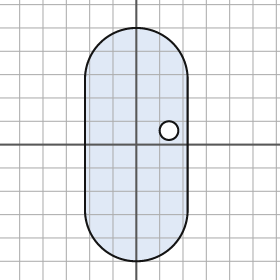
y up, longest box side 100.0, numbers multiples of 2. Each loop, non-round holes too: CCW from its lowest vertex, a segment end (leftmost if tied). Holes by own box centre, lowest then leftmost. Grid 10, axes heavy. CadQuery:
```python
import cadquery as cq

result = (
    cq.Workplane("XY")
    .moveTo(-22.0, -28.0)
    .threePointArc((0.0, -50.0), (22.0, -28.0))
    .lineTo(22.0, 28.0)
    .threePointArc((0.0, 50.0), (-22.0, 28.0))
    .close()
    .moveTo(14.0, 6.0)
    .circle(4.0)
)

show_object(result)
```